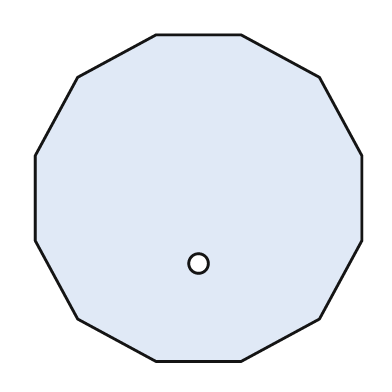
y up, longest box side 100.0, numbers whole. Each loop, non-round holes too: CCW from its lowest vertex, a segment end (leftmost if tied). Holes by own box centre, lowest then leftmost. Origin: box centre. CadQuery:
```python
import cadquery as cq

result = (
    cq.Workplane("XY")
    .moveTo(-13.0, -50.0)
    .lineTo(13.0, -50.0)
    .lineTo(37.0, -37.0)
    .lineTo(50.0, -13.0)
    .lineTo(50.0, 13.0)
    .lineTo(37.0, 37.0)
    .lineTo(13.0, 50.0)
    .lineTo(-13.0, 50.0)
    .lineTo(-37.0, 37.0)
    .lineTo(-50.0, 13.0)
    .lineTo(-50.0, -13.0)
    .lineTo(-37.0, -37.0)
    .close()
    .moveTo(0.0, -20.0)
    .circle(3.0)
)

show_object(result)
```